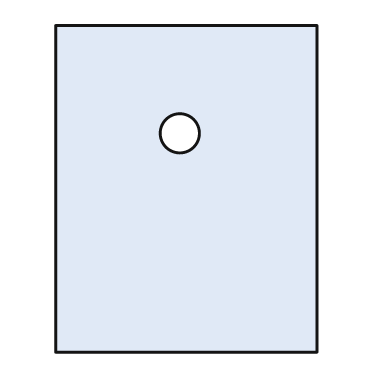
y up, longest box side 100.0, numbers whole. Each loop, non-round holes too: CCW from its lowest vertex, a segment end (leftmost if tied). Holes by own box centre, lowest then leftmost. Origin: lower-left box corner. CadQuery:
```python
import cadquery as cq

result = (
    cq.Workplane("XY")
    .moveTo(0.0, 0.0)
    .lineTo(80.0, 0.0)
    .lineTo(80.0, 100.0)
    .lineTo(0.0, 100.0)
    .close()
    .moveTo(38.0, 67.0)
    .circle(6.0)
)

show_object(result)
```